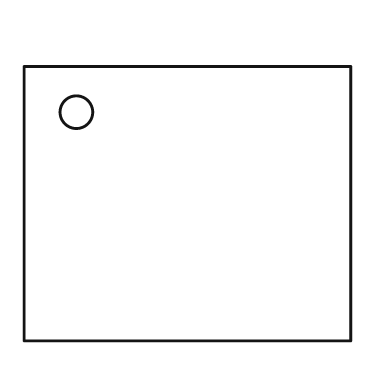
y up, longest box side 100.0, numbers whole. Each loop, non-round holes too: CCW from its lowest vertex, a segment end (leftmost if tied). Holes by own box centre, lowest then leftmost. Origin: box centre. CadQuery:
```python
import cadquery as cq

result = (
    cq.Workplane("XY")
    .moveTo(-50.0, -42.0)
    .lineTo(50.0, -42.0)
    .lineTo(50.0, 42.0)
    .lineTo(-50.0, 42.0)
    .close()
    .moveTo(-34.0, 28.0)
    .circle(5.0)
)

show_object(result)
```